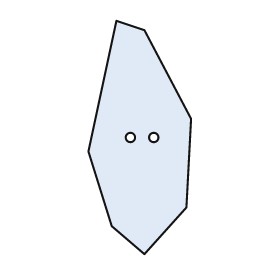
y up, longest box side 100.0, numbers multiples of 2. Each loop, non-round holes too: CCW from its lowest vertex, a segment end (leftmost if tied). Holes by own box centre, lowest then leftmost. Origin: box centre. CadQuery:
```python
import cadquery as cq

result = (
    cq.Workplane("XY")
    .moveTo(2.0, -50.0)
    .lineTo(20.0, -30.0)
    .lineTo(22.0, 8.0)
    .lineTo(2.0, 46.0)
    .lineTo(-10.0, 50.0)
    .lineTo(-22.0, -6.0)
    .lineTo(-12.0, -38.0)
    .close()
    .moveTo(-4.0, 0.0)
    .circle(2.0)
    .moveTo(6.0, 0.0)
    .circle(2.0)
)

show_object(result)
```